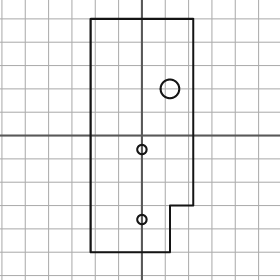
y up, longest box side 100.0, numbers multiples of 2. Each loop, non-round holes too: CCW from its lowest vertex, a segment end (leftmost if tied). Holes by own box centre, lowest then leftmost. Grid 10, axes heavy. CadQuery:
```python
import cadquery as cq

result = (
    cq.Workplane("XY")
    .moveTo(-22.0, -50.0)
    .lineTo(12.0, -50.0)
    .lineTo(12.0, -30.0)
    .lineTo(22.0, -30.0)
    .lineTo(22.0, 50.0)
    .lineTo(-22.0, 50.0)
    .close()
    .moveTo(0.0, -36.0)
    .circle(2.0)
    .moveTo(0.0, -6.0)
    .circle(2.0)
    .moveTo(12.0, 20.0)
    .circle(4.0)
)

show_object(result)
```